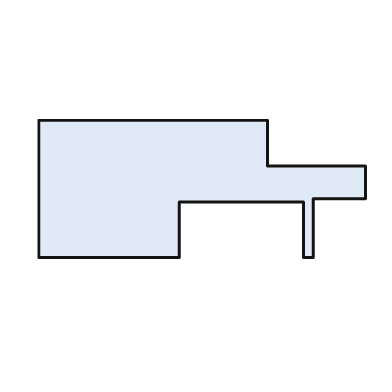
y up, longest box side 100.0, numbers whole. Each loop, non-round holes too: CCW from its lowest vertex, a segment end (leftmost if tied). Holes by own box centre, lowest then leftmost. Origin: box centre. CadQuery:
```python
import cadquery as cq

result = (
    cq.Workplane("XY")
    .moveTo(-50.0, -21.0)
    .lineTo(-7.0, -21.0)
    .lineTo(-7.0, -4.0)
    .lineTo(31.0, -4.0)
    .lineTo(31.0, -21.0)
    .lineTo(34.0, -21.0)
    .lineTo(34.0, -3.0)
    .lineTo(50.0, -3.0)
    .lineTo(50.0, 7.0)
    .lineTo(20.0, 7.0)
    .lineTo(20.0, 21.0)
    .lineTo(-50.0, 21.0)
    .close()
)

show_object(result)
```